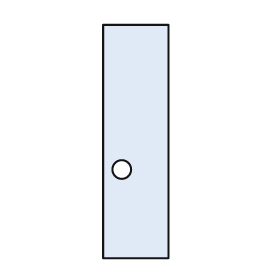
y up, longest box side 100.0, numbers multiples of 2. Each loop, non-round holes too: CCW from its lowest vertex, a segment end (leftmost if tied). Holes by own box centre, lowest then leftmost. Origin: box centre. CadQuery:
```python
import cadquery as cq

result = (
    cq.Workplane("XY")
    .moveTo(-14.0, -50.0)
    .lineTo(14.0, -50.0)
    .lineTo(14.0, 50.0)
    .lineTo(-14.0, 50.0)
    .close()
    .moveTo(-6.0, -12.0)
    .circle(4.0)
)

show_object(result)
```